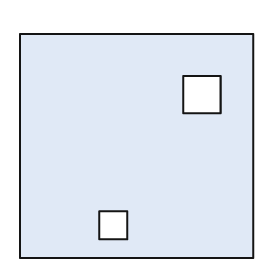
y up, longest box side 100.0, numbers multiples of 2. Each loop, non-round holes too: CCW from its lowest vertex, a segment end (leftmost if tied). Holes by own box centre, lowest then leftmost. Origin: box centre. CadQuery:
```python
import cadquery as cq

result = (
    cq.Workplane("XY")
    .moveTo(-50.0, -48.0)
    .lineTo(50.0, -48.0)
    .lineTo(50.0, 48.0)
    .lineTo(-50.0, 48.0)
    .close()
    .moveTo(-16.0, -40.0)
    .lineTo(-4.0, -40.0)
    .lineTo(-4.0, -28.0)
    .lineTo(-16.0, -28.0)
    .close()
    .moveTo(20.0, 14.0)
    .lineTo(36.0, 14.0)
    .lineTo(36.0, 30.0)
    .lineTo(20.0, 30.0)
    .close()
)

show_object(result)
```